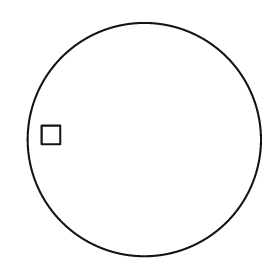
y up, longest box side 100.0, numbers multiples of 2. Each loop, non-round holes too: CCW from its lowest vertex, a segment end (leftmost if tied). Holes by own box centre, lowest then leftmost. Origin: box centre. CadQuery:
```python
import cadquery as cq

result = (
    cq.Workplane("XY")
    .moveTo(0.0, 0.0)
    .circle(50.0)
    .moveTo(-44.0, -2.0)
    .lineTo(-36.0, -2.0)
    .lineTo(-36.0, 6.0)
    .lineTo(-44.0, 6.0)
    .close()
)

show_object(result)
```